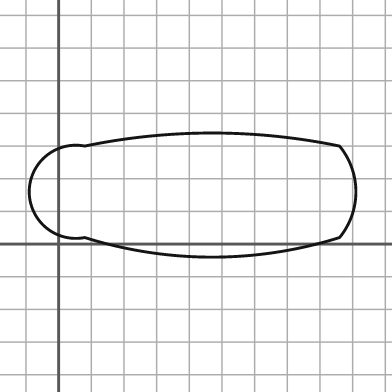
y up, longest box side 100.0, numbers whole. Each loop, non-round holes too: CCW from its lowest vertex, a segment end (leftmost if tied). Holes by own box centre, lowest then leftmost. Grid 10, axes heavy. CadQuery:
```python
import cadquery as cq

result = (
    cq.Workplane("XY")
    .moveTo(8.0, 2.0)
    .threePointArc((47.0, -4.0), (86.0, 2.0))
    .threePointArc((91.0, 16.0), (86.0, 30.0))
    .threePointArc((47.0, 34.0), (8.0, 30.0))
    .threePointArc((-9.0, 16.0), (8.0, 2.0))
    .close()
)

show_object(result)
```